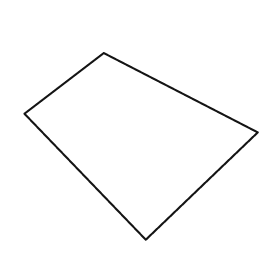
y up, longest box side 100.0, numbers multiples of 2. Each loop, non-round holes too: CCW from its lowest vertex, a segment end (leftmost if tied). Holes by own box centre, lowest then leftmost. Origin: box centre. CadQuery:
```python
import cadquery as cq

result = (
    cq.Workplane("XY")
    .moveTo(2.0, -40.0)
    .lineTo(50.0, 6.0)
    .lineTo(-16.0, 40.0)
    .lineTo(-50.0, 14.0)
    .close()
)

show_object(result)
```